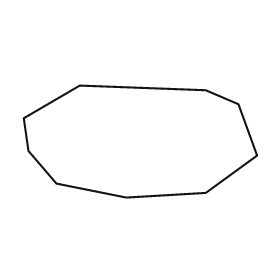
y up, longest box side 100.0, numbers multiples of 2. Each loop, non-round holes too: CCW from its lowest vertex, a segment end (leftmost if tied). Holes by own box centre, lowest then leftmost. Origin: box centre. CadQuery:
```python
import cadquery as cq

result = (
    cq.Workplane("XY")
    .moveTo(-6.0, -24.0)
    .lineTo(28.0, -22.0)
    .lineTo(50.0, -6.0)
    .lineTo(42.0, 16.0)
    .lineTo(28.0, 22.0)
    .lineTo(-26.0, 24.0)
    .lineTo(-50.0, 10.0)
    .lineTo(-48.0, -4.0)
    .lineTo(-36.0, -18.0)
    .close()
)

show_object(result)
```